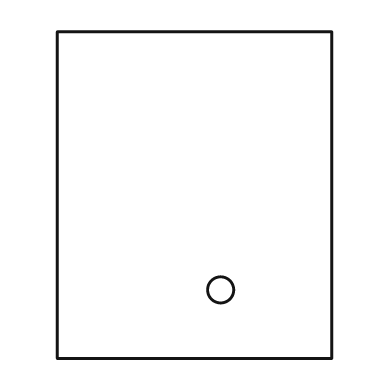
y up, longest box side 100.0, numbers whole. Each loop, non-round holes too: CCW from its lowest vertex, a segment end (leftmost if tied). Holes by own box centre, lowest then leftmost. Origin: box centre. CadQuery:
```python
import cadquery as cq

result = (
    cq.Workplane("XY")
    .moveTo(-42.0, -50.0)
    .lineTo(42.0, -50.0)
    .lineTo(42.0, 50.0)
    .lineTo(-42.0, 50.0)
    .close()
    .moveTo(8.0, -29.0)
    .circle(4.0)
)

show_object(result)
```